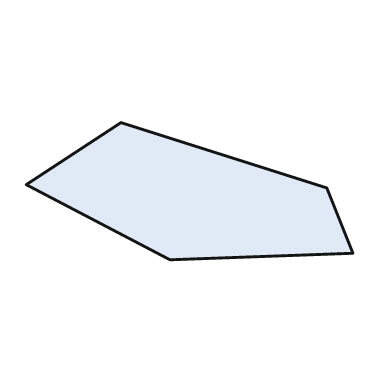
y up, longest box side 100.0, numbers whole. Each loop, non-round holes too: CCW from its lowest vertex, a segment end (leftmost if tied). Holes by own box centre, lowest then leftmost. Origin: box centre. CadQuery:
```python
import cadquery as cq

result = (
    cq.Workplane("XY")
    .moveTo(-6.0, -21.0)
    .lineTo(50.0, -19.0)
    .lineTo(42.0, 1.0)
    .lineTo(-21.0, 21.0)
    .lineTo(-50.0, 2.0)
    .close()
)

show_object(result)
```